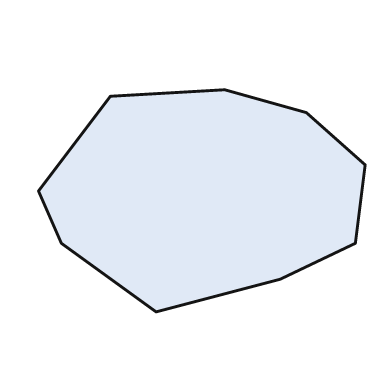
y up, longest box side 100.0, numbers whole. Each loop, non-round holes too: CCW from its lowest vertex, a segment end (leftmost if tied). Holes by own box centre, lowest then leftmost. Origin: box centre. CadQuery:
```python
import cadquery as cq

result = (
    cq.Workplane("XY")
    .moveTo(-14.0, -34.0)
    .lineTo(24.0, -24.0)
    .lineTo(47.0, -13.0)
    .lineTo(50.0, 11.0)
    .lineTo(32.0, 27.0)
    .lineTo(7.0, 34.0)
    .lineTo(-28.0, 32.0)
    .lineTo(-50.0, 3.0)
    .lineTo(-43.0, -13.0)
    .close()
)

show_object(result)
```